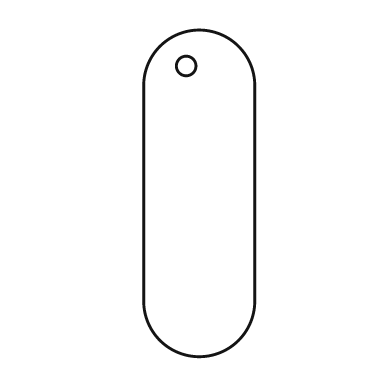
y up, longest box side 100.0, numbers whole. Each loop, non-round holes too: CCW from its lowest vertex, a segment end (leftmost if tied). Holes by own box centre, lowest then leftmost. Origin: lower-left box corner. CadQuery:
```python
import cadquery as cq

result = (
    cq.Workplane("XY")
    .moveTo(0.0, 17.0)
    .threePointArc((17.0, 0.0), (34.0, 17.0))
    .lineTo(34.0, 83.0)
    .threePointArc((17.0, 100.0), (0.0, 83.0))
    .close()
    .moveTo(13.0, 89.0)
    .circle(3.0)
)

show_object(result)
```